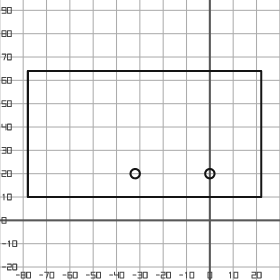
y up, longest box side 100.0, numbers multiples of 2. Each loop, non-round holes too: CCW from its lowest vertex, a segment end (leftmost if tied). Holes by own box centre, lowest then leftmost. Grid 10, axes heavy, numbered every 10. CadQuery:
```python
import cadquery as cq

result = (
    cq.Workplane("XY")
    .moveTo(-78.0, 10.0)
    .lineTo(22.0, 10.0)
    .lineTo(22.0, 64.0)
    .lineTo(-78.0, 64.0)
    .close()
    .moveTo(-32.0, 20.0)
    .circle(2.0)
    .moveTo(0.0, 20.0)
    .circle(2.0)
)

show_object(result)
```